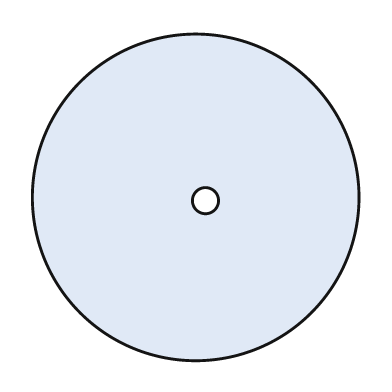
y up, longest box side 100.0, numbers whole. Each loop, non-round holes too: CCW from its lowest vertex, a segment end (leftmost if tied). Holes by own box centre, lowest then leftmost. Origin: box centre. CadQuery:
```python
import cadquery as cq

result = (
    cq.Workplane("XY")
    .moveTo(0.0, 0.0)
    .circle(50.0)
    .moveTo(3.0, -1.0)
    .circle(4.0)
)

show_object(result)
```